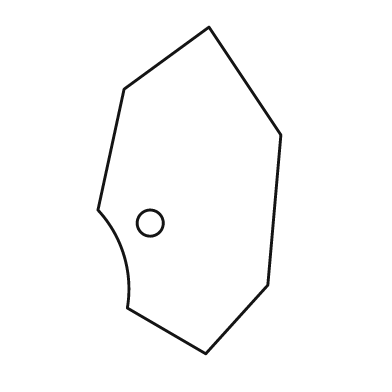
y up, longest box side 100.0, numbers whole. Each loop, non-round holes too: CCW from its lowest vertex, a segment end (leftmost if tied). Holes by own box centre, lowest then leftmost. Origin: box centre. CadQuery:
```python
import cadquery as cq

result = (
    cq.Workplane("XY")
    .moveTo(5.0, -50.0)
    .lineTo(24.0, -29.0)
    .lineTo(28.0, 17.0)
    .lineTo(6.0, 50.0)
    .lineTo(-20.0, 31.0)
    .lineTo(-28.0, -6.0)
    .threePointArc((-20.0, -20.0), (-19.0, -36.0))
    .close()
    .moveTo(-12.0, -10.0)
    .circle(4.0)
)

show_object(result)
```